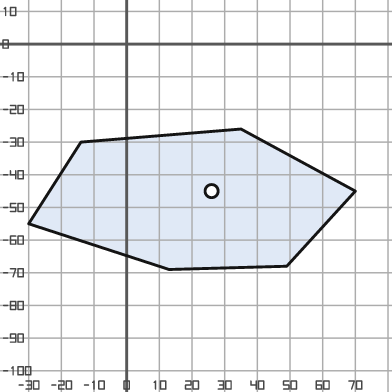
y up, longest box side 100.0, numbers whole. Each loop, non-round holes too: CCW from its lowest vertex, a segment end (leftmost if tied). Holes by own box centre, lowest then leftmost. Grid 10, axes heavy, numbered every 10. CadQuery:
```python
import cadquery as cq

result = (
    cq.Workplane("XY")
    .moveTo(13.0, -69.0)
    .lineTo(49.0, -68.0)
    .lineTo(70.0, -45.0)
    .lineTo(35.0, -26.0)
    .lineTo(-14.0, -30.0)
    .lineTo(-30.0, -55.0)
    .close()
    .moveTo(26.0, -45.0)
    .circle(2.0)
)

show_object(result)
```